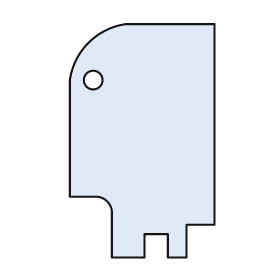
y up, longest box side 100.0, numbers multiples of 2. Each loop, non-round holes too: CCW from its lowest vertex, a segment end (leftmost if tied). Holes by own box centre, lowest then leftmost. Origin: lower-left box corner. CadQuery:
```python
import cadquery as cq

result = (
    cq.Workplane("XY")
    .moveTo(18.0, 0.0)
    .lineTo(32.0, 0.0)
    .lineTo(32.0, 10.0)
    .lineTo(42.0, 10.0)
    .lineTo(42.0, 0.0)
    .lineTo(50.0, 0.0)
    .lineTo(50.0, 14.0)
    .lineTo(62.0, 14.0)
    .lineTo(62.0, 100.0)
    .lineTo(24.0, 100.0)
    .threePointArc((8.0, 92.0), (0.0, 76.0))
    .lineTo(0.0, 26.0)
    .lineTo(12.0, 26.0)
    .threePointArc((16.0, 24.0), (18.0, 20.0))
    .close()
    .moveTo(10.0, 76.0)
    .circle(4.0)
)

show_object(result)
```